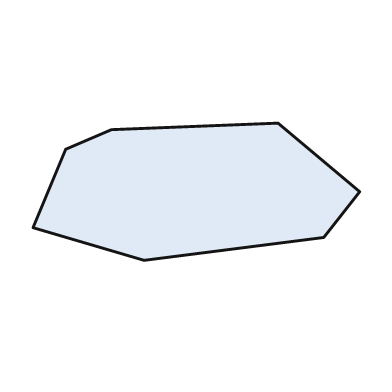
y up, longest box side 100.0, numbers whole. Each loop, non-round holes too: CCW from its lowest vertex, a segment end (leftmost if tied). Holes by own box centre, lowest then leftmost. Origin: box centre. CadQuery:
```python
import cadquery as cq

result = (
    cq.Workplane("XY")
    .moveTo(-16.0, -21.0)
    .lineTo(39.0, -14.0)
    .lineTo(50.0, 0.0)
    .lineTo(25.0, 21.0)
    .lineTo(-26.0, 19.0)
    .lineTo(-40.0, 13.0)
    .lineTo(-50.0, -11.0)
    .close()
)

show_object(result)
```